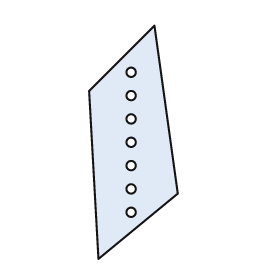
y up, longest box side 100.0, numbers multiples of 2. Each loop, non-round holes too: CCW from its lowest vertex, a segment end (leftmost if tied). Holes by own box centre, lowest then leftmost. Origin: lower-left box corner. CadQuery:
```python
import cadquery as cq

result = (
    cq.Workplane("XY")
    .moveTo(4.0, 0.0)
    .lineTo(38.0, 28.0)
    .lineTo(28.0, 100.0)
    .lineTo(0.0, 72.0)
    .close()
    .moveTo(18.0, 20.0)
    .circle(2.0)
    .moveTo(18.0, 30.0)
    .circle(2.0)
    .moveTo(18.0, 40.0)
    .circle(2.0)
    .moveTo(18.0, 50.0)
    .circle(2.0)
    .moveTo(18.0, 60.0)
    .circle(2.0)
    .moveTo(18.0, 70.0)
    .circle(2.0)
    .moveTo(18.0, 80.0)
    .circle(2.0)
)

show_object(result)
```